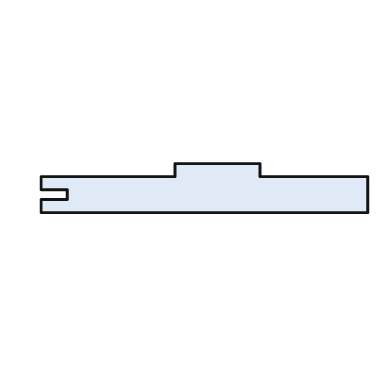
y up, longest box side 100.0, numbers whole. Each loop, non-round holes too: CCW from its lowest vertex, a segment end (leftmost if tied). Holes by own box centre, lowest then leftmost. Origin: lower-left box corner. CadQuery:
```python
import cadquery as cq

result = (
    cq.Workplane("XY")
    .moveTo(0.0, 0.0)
    .lineTo(100.0, 0.0)
    .lineTo(100.0, 11.0)
    .lineTo(67.0, 11.0)
    .lineTo(67.0, 15.0)
    .lineTo(41.0, 15.0)
    .lineTo(41.0, 11.0)
    .lineTo(0.0, 11.0)
    .lineTo(0.0, 7.0)
    .lineTo(8.0, 7.0)
    .lineTo(8.0, 4.0)
    .lineTo(0.0, 4.0)
    .close()
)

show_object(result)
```